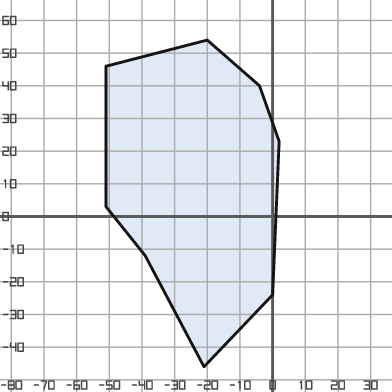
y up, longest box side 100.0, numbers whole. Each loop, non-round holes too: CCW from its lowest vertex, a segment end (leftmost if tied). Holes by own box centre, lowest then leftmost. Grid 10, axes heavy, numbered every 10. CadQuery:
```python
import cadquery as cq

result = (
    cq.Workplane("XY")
    .moveTo(-21.0, -46.0)
    .lineTo(0.0, -24.0)
    .lineTo(2.0, 23.0)
    .lineTo(-4.0, 40.0)
    .lineTo(-20.0, 54.0)
    .lineTo(-51.0, 46.0)
    .lineTo(-51.0, 3.0)
    .lineTo(-39.0, -12.0)
    .close()
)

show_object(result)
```